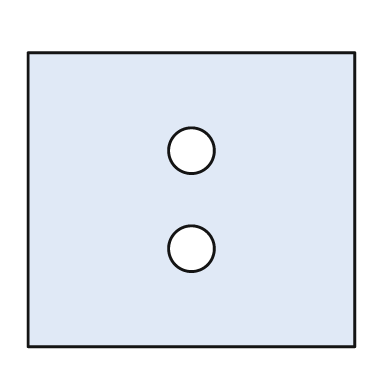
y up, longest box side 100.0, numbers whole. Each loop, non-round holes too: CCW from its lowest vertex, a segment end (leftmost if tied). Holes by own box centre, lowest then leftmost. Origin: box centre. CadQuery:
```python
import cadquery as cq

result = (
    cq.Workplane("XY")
    .moveTo(-50.0, -45.0)
    .lineTo(50.0, -45.0)
    .lineTo(50.0, 45.0)
    .lineTo(-50.0, 45.0)
    .close()
    .moveTo(0.0, -15.0)
    .circle(7.0)
    .moveTo(0.0, 15.0)
    .circle(7.0)
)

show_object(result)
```